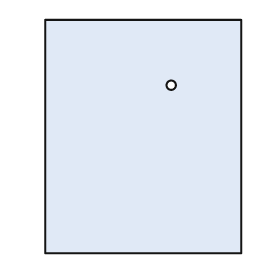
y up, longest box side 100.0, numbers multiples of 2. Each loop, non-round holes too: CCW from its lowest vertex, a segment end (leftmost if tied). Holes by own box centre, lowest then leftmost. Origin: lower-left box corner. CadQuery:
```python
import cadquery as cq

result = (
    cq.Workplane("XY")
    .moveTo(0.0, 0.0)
    .lineTo(84.0, 0.0)
    .lineTo(84.0, 100.0)
    .lineTo(0.0, 100.0)
    .close()
    .moveTo(54.0, 72.0)
    .circle(2.0)
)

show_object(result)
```